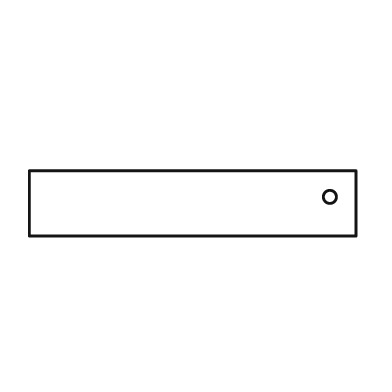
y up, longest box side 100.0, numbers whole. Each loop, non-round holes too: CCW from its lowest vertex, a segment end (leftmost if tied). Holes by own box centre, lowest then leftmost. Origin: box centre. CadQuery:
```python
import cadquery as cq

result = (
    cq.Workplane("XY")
    .moveTo(-50.0, -10.0)
    .lineTo(50.0, -10.0)
    .lineTo(50.0, 10.0)
    .lineTo(-50.0, 10.0)
    .close()
    .moveTo(42.0, 2.0)
    .circle(2.0)
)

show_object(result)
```